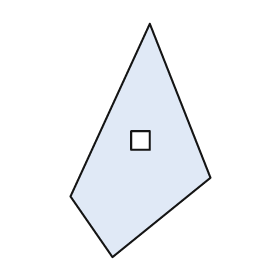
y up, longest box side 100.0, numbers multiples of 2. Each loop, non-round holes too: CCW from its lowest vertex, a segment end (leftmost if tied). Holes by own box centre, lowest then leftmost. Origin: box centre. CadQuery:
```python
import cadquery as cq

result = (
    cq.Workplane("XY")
    .moveTo(-12.0, -50.0)
    .lineTo(30.0, -16.0)
    .lineTo(4.0, 50.0)
    .lineTo(-30.0, -24.0)
    .close()
    .moveTo(-4.0, -4.0)
    .lineTo(4.0, -4.0)
    .lineTo(4.0, 4.0)
    .lineTo(-4.0, 4.0)
    .close()
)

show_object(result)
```